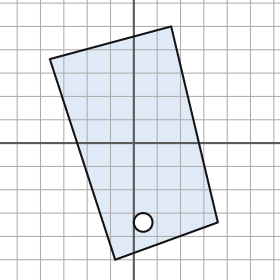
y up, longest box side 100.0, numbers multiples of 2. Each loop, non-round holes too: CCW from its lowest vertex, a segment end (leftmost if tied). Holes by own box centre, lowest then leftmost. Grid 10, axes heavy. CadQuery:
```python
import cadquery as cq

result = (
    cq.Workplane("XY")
    .moveTo(-8.0, -50.0)
    .lineTo(36.0, -34.0)
    .lineTo(16.0, 50.0)
    .lineTo(-36.0, 36.0)
    .close()
    .moveTo(4.0, -34.0)
    .circle(4.0)
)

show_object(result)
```